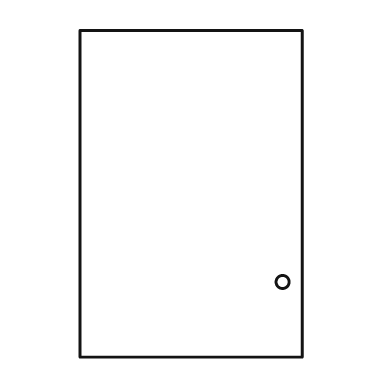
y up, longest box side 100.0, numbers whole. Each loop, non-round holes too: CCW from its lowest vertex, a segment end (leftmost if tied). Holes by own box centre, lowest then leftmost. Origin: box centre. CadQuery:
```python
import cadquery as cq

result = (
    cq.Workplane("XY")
    .moveTo(-34.0, -50.0)
    .lineTo(34.0, -50.0)
    .lineTo(34.0, 50.0)
    .lineTo(-34.0, 50.0)
    .close()
    .moveTo(28.0, -27.0)
    .circle(2.0)
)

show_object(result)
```